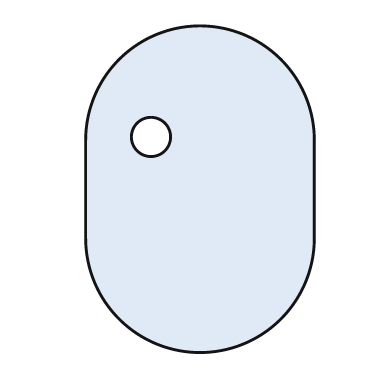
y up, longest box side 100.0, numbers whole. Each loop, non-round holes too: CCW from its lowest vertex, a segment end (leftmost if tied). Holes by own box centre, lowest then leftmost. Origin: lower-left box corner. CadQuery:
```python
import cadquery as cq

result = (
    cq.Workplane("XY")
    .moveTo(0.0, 35.0)
    .threePointArc((35.0, 0.0), (70.0, 35.0))
    .lineTo(70.0, 65.0)
    .threePointArc((35.0, 100.0), (0.0, 65.0))
    .close()
    .moveTo(20.0, 66.0)
    .circle(6.0)
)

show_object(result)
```